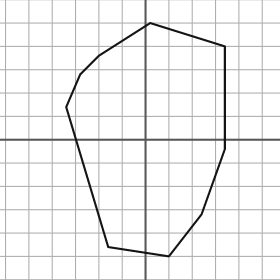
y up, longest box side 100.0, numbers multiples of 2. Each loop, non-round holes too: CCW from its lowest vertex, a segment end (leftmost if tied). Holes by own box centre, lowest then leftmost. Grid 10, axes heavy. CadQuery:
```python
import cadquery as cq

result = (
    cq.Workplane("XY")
    .moveTo(10.0, -50.0)
    .lineTo(24.0, -32.0)
    .lineTo(34.0, -4.0)
    .lineTo(34.0, 40.0)
    .lineTo(2.0, 50.0)
    .lineTo(-20.0, 36.0)
    .lineTo(-28.0, 28.0)
    .lineTo(-34.0, 14.0)
    .lineTo(-16.0, -46.0)
    .close()
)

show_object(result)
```